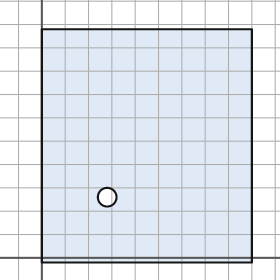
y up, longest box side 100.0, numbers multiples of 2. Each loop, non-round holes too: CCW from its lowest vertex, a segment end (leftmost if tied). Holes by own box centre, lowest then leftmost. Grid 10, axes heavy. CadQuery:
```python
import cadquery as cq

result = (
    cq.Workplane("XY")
    .moveTo(0.0, -2.0)
    .lineTo(90.0, -2.0)
    .lineTo(90.0, 98.0)
    .lineTo(0.0, 98.0)
    .close()
    .moveTo(28.0, 26.0)
    .circle(4.0)
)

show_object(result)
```